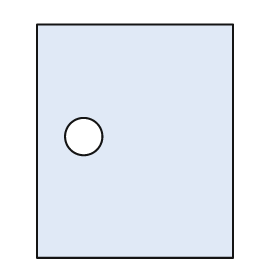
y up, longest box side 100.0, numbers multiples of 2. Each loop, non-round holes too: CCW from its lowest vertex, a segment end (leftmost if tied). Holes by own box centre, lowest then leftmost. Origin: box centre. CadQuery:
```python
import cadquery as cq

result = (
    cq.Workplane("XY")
    .moveTo(-42.0, -50.0)
    .lineTo(42.0, -50.0)
    .lineTo(42.0, 50.0)
    .lineTo(-42.0, 50.0)
    .close()
    .moveTo(-22.0, 2.0)
    .circle(8.0)
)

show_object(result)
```